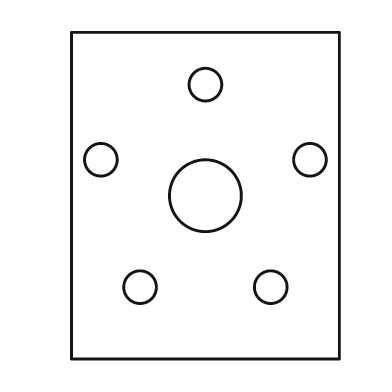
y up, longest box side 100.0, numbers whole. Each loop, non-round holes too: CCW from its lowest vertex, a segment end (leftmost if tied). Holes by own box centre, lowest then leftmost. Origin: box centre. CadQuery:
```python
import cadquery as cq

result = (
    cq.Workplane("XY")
    .moveTo(-41.0, -50.0)
    .lineTo(41.0, -50.0)
    .lineTo(41.0, 50.0)
    .lineTo(-41.0, 50.0)
    .close()
    .moveTo(-20.0, -28.0)
    .circle(5.0)
    .moveTo(20.0, -28.0)
    .circle(5.0)
    .moveTo(0.0, 0.0)
    .circle(11.0)
    .moveTo(-32.0, 11.0)
    .circle(5.0)
    .moveTo(32.0, 11.0)
    .circle(5.0)
    .moveTo(0.0, 34.0)
    .circle(5.0)
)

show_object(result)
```